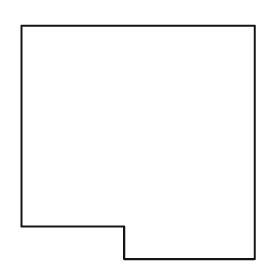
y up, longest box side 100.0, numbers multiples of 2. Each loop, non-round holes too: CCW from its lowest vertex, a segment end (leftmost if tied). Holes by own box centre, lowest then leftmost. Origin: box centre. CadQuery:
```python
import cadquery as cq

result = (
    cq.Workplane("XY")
    .moveTo(-6.0, -50.0)
    .lineTo(50.0, -50.0)
    .lineTo(50.0, 50.0)
    .lineTo(-50.0, 50.0)
    .lineTo(-50.0, -36.0)
    .lineTo(-6.0, -36.0)
    .close()
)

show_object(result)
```